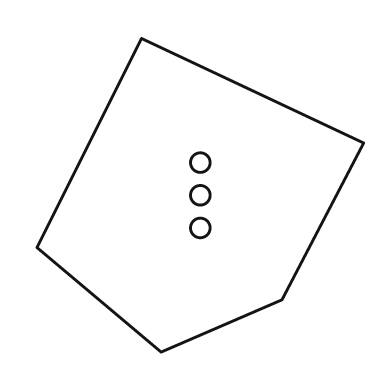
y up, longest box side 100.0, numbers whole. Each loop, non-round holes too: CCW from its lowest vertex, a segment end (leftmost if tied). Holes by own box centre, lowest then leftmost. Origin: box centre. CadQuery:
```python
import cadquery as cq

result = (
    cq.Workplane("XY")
    .moveTo(-12.0, -48.0)
    .lineTo(25.0, -32.0)
    .lineTo(50.0, 16.0)
    .lineTo(-18.0, 48.0)
    .lineTo(-50.0, -16.0)
    .close()
    .moveTo(0.0, -10.0)
    .circle(3.0)
    .moveTo(0.0, 0.0)
    .circle(3.0)
    .moveTo(0.0, 10.0)
    .circle(3.0)
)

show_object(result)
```